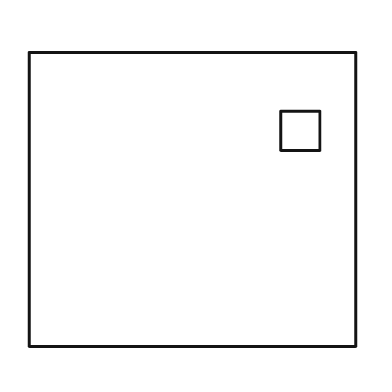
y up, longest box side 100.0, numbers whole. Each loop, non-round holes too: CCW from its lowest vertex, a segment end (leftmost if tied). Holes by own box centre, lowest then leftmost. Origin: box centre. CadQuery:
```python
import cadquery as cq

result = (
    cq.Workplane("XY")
    .moveTo(-50.0, -45.0)
    .lineTo(50.0, -45.0)
    .lineTo(50.0, 45.0)
    .lineTo(-50.0, 45.0)
    .close()
    .moveTo(27.0, 15.0)
    .lineTo(39.0, 15.0)
    .lineTo(39.0, 27.0)
    .lineTo(27.0, 27.0)
    .close()
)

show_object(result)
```